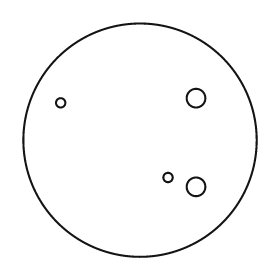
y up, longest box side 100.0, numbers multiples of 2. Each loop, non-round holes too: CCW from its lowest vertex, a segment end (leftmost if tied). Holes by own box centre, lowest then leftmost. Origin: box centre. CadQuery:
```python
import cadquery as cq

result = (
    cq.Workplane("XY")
    .moveTo(0.0, 0.0)
    .circle(50.0)
    .moveTo(24.0, -20.0)
    .circle(4.0)
    .moveTo(12.0, -16.0)
    .circle(2.0)
    .moveTo(-34.0, 16.0)
    .circle(2.0)
    .moveTo(24.0, 18.0)
    .circle(4.0)
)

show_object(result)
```